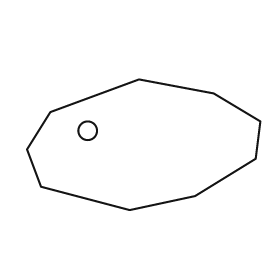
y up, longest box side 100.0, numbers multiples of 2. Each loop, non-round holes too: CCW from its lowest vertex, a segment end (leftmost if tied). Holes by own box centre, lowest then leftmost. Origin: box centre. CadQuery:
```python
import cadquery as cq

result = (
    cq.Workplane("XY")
    .moveTo(-6.0, -28.0)
    .lineTo(22.0, -22.0)
    .lineTo(48.0, -6.0)
    .lineTo(50.0, 10.0)
    .lineTo(30.0, 22.0)
    .lineTo(-2.0, 28.0)
    .lineTo(-40.0, 14.0)
    .lineTo(-50.0, -2.0)
    .lineTo(-44.0, -18.0)
    .close()
    .moveTo(-24.0, 6.0)
    .circle(4.0)
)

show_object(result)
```